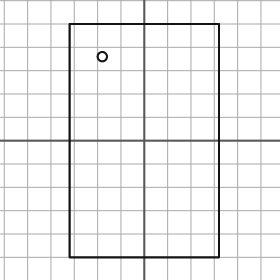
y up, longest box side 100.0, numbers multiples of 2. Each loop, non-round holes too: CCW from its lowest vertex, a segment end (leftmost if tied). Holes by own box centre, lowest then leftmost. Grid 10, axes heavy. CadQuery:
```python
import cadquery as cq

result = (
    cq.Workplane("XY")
    .moveTo(-32.0, -50.0)
    .lineTo(32.0, -50.0)
    .lineTo(32.0, 50.0)
    .lineTo(-32.0, 50.0)
    .close()
    .moveTo(-18.0, 36.0)
    .circle(2.0)
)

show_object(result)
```